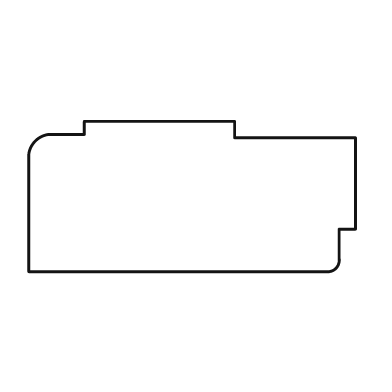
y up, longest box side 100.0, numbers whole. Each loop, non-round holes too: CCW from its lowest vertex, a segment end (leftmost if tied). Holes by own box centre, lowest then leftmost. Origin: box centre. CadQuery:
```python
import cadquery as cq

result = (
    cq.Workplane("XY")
    .moveTo(-50.0, -23.0)
    .lineTo(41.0, -23.0)
    .threePointArc((44.0, -22.0), (45.0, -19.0))
    .lineTo(45.0, -10.0)
    .lineTo(50.0, -10.0)
    .lineTo(50.0, 18.0)
    .lineTo(13.0, 18.0)
    .lineTo(13.0, 23.0)
    .lineTo(-33.0, 23.0)
    .lineTo(-33.0, 19.0)
    .lineTo(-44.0, 19.0)
    .threePointArc((-48.0, 17.0), (-50.0, 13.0))
    .close()
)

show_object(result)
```